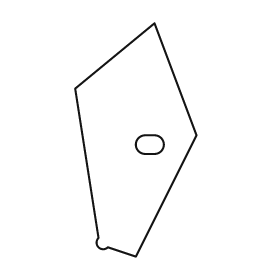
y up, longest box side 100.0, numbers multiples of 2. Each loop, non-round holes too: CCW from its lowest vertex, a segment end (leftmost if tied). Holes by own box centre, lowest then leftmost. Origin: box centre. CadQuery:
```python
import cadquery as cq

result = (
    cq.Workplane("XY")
    .moveTo(0.0, -50.0)
    .lineTo(26.0, 2.0)
    .lineTo(8.0, 50.0)
    .lineTo(-26.0, 22.0)
    .lineTo(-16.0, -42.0)
    .threePointArc((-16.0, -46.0), (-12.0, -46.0))
    .close()
    .moveTo(4.0, -6.0)
    .lineTo(8.0, -6.0)
    .threePointArc((12.0, -2.0), (8.0, 2.0))
    .lineTo(4.0, 2.0)
    .threePointArc((0.0, -2.0), (4.0, -6.0))
    .close()
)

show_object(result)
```